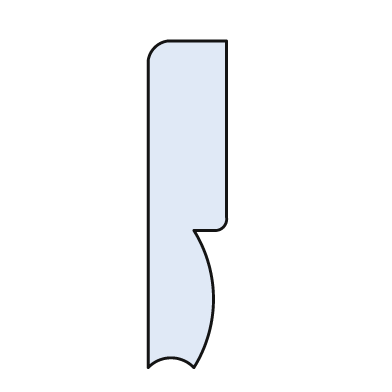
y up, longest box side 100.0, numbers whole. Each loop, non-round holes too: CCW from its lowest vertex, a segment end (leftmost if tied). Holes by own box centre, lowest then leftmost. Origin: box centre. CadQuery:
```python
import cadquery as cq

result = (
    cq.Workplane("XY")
    .moveTo(-12.0, -50.0)
    .threePointArc((-5.0, -47.0), (2.0, -50.0))
    .threePointArc((8.0, -29.0), (2.0, -8.0))
    .lineTo(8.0, -8.0)
    .threePointArc((11.0, -7.0), (12.0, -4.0))
    .lineTo(12.0, 50.0)
    .lineTo(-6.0, 50.0)
    .threePointArc((-10.0, 48.0), (-12.0, 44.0))
    .close()
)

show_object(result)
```